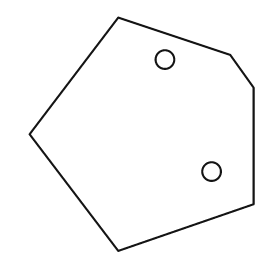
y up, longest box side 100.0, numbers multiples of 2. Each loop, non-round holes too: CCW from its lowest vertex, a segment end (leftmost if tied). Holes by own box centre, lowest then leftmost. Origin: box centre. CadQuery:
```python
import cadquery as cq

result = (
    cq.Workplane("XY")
    .moveTo(-10.0, -50.0)
    .lineTo(48.0, -30.0)
    .lineTo(48.0, 20.0)
    .lineTo(38.0, 34.0)
    .lineTo(-10.0, 50.0)
    .lineTo(-48.0, 0.0)
    .close()
    .moveTo(30.0, -16.0)
    .circle(4.0)
    .moveTo(10.0, 32.0)
    .circle(4.0)
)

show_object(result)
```